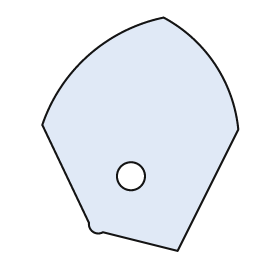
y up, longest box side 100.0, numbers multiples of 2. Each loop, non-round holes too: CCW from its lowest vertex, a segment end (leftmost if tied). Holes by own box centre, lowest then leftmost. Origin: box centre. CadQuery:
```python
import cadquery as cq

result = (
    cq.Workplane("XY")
    .moveTo(16.0, -50.0)
    .lineTo(42.0, 2.0)
    .threePointArc((32.0, 30.0), (10.0, 50.0))
    .threePointArc((-22.0, 34.0), (-42.0, 4.0))
    .lineTo(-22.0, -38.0)
    .threePointArc((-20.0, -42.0), (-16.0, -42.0))
    .close()
    .moveTo(-4.0, -18.0)
    .circle(6.0)
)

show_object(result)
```